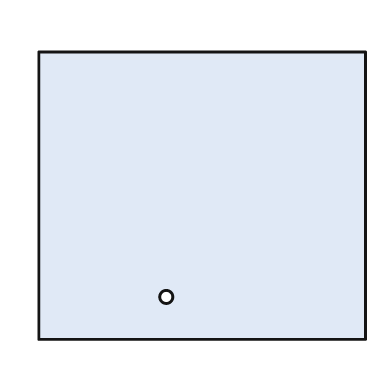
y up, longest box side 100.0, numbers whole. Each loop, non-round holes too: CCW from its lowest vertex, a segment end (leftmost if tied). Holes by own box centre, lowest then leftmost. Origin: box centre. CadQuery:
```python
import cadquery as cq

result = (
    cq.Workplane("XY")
    .moveTo(-50.0, -44.0)
    .lineTo(50.0, -44.0)
    .lineTo(50.0, 44.0)
    .lineTo(-50.0, 44.0)
    .close()
    .moveTo(-11.0, -31.0)
    .circle(2.0)
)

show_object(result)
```